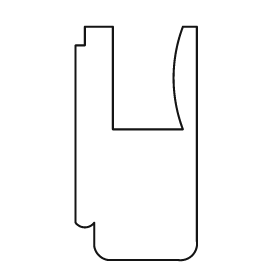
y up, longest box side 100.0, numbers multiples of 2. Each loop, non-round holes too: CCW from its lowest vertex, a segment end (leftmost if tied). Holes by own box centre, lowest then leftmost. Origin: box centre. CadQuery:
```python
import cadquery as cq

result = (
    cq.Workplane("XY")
    .moveTo(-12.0, -50.0)
    .lineTo(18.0, -50.0)
    .threePointArc((24.0, -48.0), (26.0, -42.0))
    .lineTo(26.0, 50.0)
    .lineTo(20.0, 50.0)
    .threePointArc((16.0, 28.0), (20.0, 6.0))
    .lineTo(-10.0, 6.0)
    .lineTo(-10.0, 50.0)
    .lineTo(-22.0, 50.0)
    .lineTo(-22.0, 42.0)
    .lineTo(-26.0, 42.0)
    .lineTo(-26.0, -34.0)
    .threePointArc((-22.0, -36.0), (-18.0, -34.0))
    .lineTo(-18.0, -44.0)
    .threePointArc((-16.0, -48.0), (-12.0, -50.0))
    .close()
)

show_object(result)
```